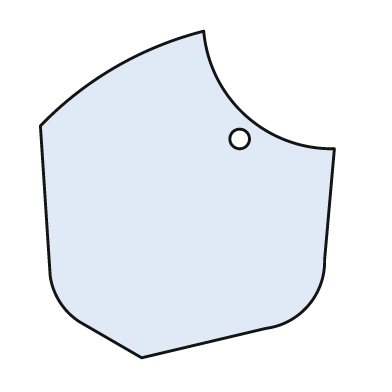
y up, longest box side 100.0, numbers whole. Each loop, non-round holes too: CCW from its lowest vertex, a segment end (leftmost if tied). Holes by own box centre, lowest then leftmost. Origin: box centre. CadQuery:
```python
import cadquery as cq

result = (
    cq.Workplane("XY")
    .moveTo(-14.0, -50.0)
    .lineTo(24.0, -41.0)
    .threePointArc((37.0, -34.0), (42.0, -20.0))
    .lineTo(45.0, 14.0)
    .threePointArc((18.0, 24.0), (5.0, 50.0))
    .threePointArc((-22.0, 39.0), (-45.0, 21.0))
    .lineTo(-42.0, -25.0)
    .threePointArc((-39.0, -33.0), (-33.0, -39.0))
    .close()
    .moveTo(16.0, 17.0)
    .circle(3.0)
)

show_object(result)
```